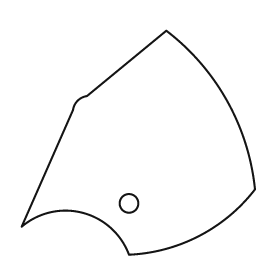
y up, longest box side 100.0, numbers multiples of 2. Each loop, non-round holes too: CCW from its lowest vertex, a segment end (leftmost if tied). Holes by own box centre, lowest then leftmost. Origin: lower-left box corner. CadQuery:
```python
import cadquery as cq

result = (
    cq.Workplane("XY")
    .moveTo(46.0, 0.0)
    .threePointArc((76.0, 8.0), (100.0, 28.0))
    .threePointArc((88.0, 66.0), (62.0, 96.0))
    .lineTo(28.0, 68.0)
    .threePointArc((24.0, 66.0), (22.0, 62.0))
    .lineTo(0.0, 12.0)
    .threePointArc((26.0, 18.0), (46.0, 0.0))
    .close()
    .moveTo(46.0, 22.0)
    .circle(4.0)
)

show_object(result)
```